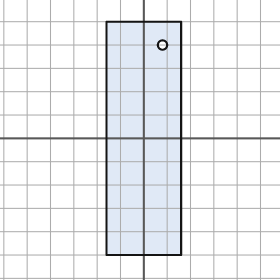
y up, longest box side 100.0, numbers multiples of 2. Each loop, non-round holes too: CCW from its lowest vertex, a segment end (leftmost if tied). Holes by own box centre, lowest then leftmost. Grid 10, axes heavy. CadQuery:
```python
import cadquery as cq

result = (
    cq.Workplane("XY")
    .moveTo(-16.0, -50.0)
    .lineTo(16.0, -50.0)
    .lineTo(16.0, 50.0)
    .lineTo(-16.0, 50.0)
    .close()
    .moveTo(8.0, 40.0)
    .circle(2.0)
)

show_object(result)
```